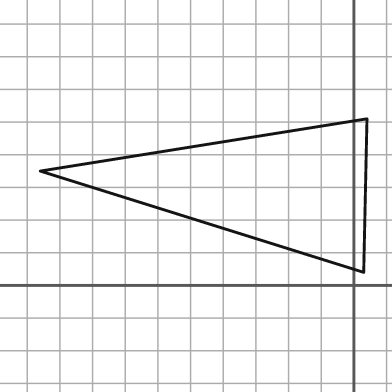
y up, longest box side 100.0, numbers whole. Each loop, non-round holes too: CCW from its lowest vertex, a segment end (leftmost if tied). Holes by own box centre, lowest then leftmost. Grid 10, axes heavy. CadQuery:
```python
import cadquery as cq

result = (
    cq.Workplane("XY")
    .moveTo(3.0, 4.0)
    .lineTo(4.0, 51.0)
    .lineTo(-96.0, 35.0)
    .close()
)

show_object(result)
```